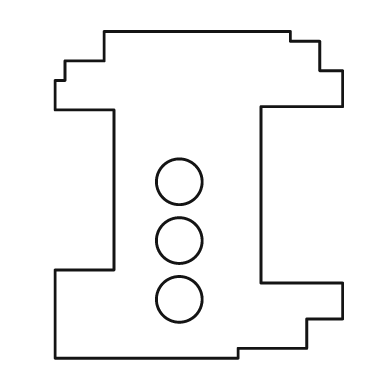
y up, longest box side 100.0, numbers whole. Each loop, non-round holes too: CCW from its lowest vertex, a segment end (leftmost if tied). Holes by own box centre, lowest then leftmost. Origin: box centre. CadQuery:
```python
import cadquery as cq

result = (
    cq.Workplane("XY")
    .moveTo(-44.0, -50.0)
    .lineTo(12.0, -50.0)
    .lineTo(12.0, -47.0)
    .lineTo(33.0, -47.0)
    .lineTo(33.0, -38.0)
    .lineTo(44.0, -38.0)
    .lineTo(44.0, -27.0)
    .lineTo(19.0, -27.0)
    .lineTo(19.0, 27.0)
    .lineTo(44.0, 27.0)
    .lineTo(44.0, 38.0)
    .lineTo(37.0, 38.0)
    .lineTo(37.0, 47.0)
    .lineTo(28.0, 47.0)
    .lineTo(28.0, 50.0)
    .lineTo(-29.0, 50.0)
    .lineTo(-29.0, 41.0)
    .lineTo(-41.0, 41.0)
    .lineTo(-41.0, 35.0)
    .lineTo(-44.0, 35.0)
    .lineTo(-44.0, 26.0)
    .lineTo(-26.0, 26.0)
    .lineTo(-26.0, -23.0)
    .lineTo(-44.0, -23.0)
    .close()
    .moveTo(-6.0, -32.0)
    .circle(7.0)
    .moveTo(-6.0, -14.0)
    .circle(7.0)
    .moveTo(-6.0, 4.0)
    .circle(7.0)
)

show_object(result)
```